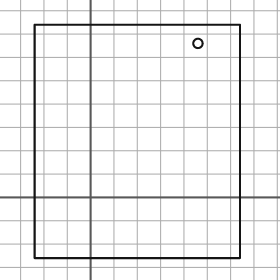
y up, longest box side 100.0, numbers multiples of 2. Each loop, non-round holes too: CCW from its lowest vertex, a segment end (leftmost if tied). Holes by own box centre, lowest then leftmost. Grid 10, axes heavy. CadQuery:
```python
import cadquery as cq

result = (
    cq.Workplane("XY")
    .moveTo(-24.0, -26.0)
    .lineTo(64.0, -26.0)
    .lineTo(64.0, 74.0)
    .lineTo(-24.0, 74.0)
    .close()
    .moveTo(46.0, 66.0)
    .circle(2.0)
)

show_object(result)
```